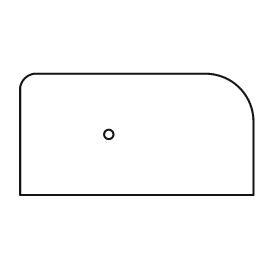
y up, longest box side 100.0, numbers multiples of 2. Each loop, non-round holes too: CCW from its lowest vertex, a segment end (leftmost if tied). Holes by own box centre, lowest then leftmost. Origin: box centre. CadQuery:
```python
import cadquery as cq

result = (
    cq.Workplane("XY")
    .moveTo(-50.0, -26.0)
    .lineTo(50.0, -26.0)
    .lineTo(50.0, 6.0)
    .threePointArc((44.0, 20.0), (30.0, 26.0))
    .lineTo(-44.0, 26.0)
    .threePointArc((-48.0, 24.0), (-50.0, 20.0))
    .close()
    .moveTo(-12.0, 0.0)
    .circle(2.0)
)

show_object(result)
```